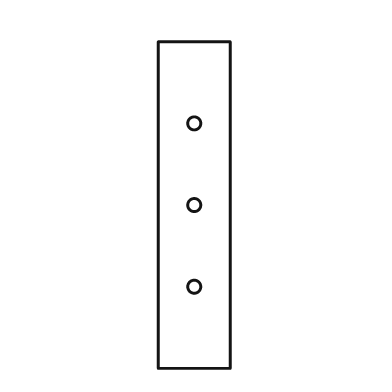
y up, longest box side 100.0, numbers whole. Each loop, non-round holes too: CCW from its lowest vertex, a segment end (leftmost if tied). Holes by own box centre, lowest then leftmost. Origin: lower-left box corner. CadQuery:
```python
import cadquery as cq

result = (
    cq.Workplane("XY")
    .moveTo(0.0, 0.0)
    .lineTo(22.0, 0.0)
    .lineTo(22.0, 100.0)
    .lineTo(0.0, 100.0)
    .close()
    .moveTo(11.0, 25.0)
    .circle(2.0)
    .moveTo(11.0, 50.0)
    .circle(2.0)
    .moveTo(11.0, 75.0)
    .circle(2.0)
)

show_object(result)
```